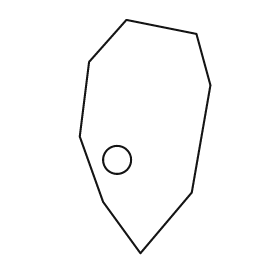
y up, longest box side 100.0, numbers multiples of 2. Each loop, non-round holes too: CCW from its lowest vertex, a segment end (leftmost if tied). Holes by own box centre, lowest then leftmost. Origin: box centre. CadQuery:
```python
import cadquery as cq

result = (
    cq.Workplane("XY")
    .moveTo(-2.0, -50.0)
    .lineTo(20.0, -24.0)
    .lineTo(28.0, 22.0)
    .lineTo(22.0, 44.0)
    .lineTo(-8.0, 50.0)
    .lineTo(-24.0, 32.0)
    .lineTo(-28.0, 0.0)
    .lineTo(-18.0, -28.0)
    .close()
    .moveTo(-12.0, -10.0)
    .circle(6.0)
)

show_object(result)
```